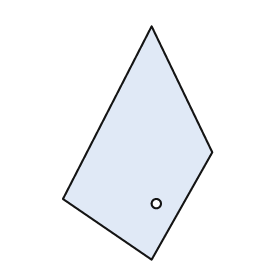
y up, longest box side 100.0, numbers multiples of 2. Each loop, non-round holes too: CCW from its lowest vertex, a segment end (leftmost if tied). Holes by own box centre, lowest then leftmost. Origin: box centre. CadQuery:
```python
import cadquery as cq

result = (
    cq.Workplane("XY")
    .moveTo(6.0, -50.0)
    .lineTo(32.0, -4.0)
    .lineTo(6.0, 50.0)
    .lineTo(-32.0, -24.0)
    .close()
    .moveTo(8.0, -26.0)
    .circle(2.0)
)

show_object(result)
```